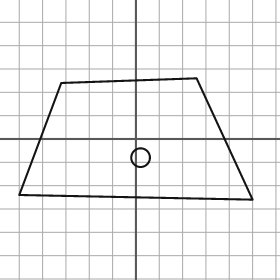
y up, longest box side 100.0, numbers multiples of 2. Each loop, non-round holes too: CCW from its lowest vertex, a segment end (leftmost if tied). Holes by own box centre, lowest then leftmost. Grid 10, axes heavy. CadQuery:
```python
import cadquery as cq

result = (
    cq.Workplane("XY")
    .moveTo(50.0, -26.0)
    .lineTo(26.0, 26.0)
    .lineTo(-32.0, 24.0)
    .lineTo(-50.0, -24.0)
    .close()
    .moveTo(2.0, -8.0)
    .circle(4.0)
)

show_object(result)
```